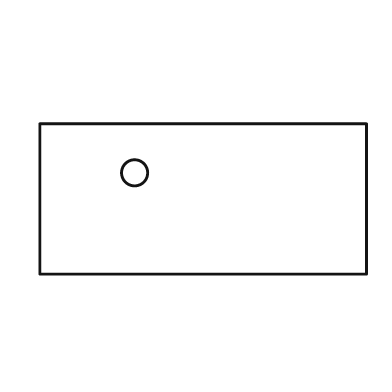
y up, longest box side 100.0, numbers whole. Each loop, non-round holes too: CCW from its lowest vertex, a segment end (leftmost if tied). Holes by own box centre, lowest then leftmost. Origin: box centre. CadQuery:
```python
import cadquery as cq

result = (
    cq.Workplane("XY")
    .moveTo(-50.0, -23.0)
    .lineTo(50.0, -23.0)
    .lineTo(50.0, 23.0)
    .lineTo(-50.0, 23.0)
    .close()
    .moveTo(-21.0, 8.0)
    .circle(4.0)
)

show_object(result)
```